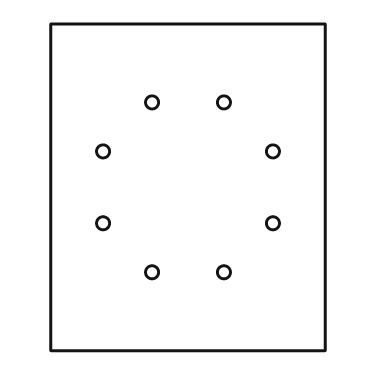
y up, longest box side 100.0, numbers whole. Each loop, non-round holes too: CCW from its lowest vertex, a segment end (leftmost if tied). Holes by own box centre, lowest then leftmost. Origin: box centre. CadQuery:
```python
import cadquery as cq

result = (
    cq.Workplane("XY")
    .moveTo(-42.0, -50.0)
    .lineTo(42.0, -50.0)
    .lineTo(42.0, 50.0)
    .lineTo(-42.0, 50.0)
    .close()
    .moveTo(-11.0, -26.0)
    .circle(2.0)
    .moveTo(11.0, -26.0)
    .circle(2.0)
    .moveTo(-26.0, -11.0)
    .circle(2.0)
    .moveTo(26.0, -11.0)
    .circle(2.0)
    .moveTo(-26.0, 11.0)
    .circle(2.0)
    .moveTo(26.0, 11.0)
    .circle(2.0)
    .moveTo(-11.0, 26.0)
    .circle(2.0)
    .moveTo(11.0, 26.0)
    .circle(2.0)
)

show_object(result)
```